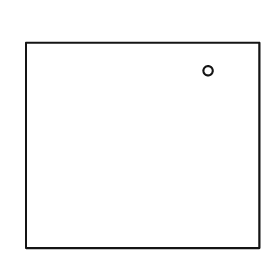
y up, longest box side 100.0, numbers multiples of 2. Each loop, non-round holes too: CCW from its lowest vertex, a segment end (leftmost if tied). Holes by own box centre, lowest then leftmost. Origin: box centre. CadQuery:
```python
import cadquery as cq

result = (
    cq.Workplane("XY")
    .moveTo(-50.0, -44.0)
    .lineTo(50.0, -44.0)
    .lineTo(50.0, 44.0)
    .lineTo(-50.0, 44.0)
    .close()
    .moveTo(28.0, 32.0)
    .circle(2.0)
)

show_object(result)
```